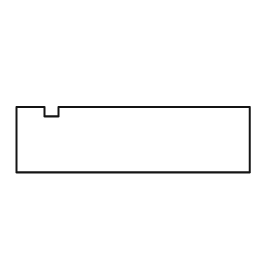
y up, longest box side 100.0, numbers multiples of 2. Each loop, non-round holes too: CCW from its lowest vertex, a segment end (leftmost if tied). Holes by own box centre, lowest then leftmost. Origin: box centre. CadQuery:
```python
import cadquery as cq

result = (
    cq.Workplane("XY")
    .moveTo(-50.0, -14.0)
    .lineTo(50.0, -14.0)
    .lineTo(50.0, 14.0)
    .lineTo(-32.0, 14.0)
    .lineTo(-32.0, 10.0)
    .lineTo(-38.0, 10.0)
    .lineTo(-38.0, 14.0)
    .lineTo(-50.0, 14.0)
    .close()
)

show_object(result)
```